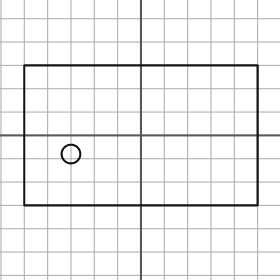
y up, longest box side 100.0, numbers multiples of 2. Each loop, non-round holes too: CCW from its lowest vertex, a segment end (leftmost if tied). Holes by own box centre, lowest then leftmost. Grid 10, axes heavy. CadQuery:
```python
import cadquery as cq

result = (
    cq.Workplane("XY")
    .moveTo(-50.0, -30.0)
    .lineTo(50.0, -30.0)
    .lineTo(50.0, 30.0)
    .lineTo(-50.0, 30.0)
    .close()
    .moveTo(-30.0, -8.0)
    .circle(4.0)
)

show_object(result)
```